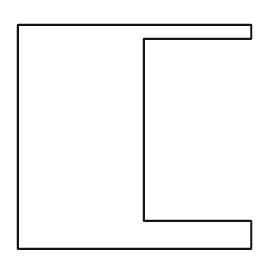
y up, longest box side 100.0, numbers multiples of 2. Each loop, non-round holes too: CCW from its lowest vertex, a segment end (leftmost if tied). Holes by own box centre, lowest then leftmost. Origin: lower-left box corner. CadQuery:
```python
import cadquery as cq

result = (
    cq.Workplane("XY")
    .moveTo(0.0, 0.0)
    .lineTo(100.0, 0.0)
    .lineTo(100.0, 12.0)
    .lineTo(54.0, 12.0)
    .lineTo(54.0, 90.0)
    .lineTo(100.0, 90.0)
    .lineTo(100.0, 96.0)
    .lineTo(0.0, 96.0)
    .close()
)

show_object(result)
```